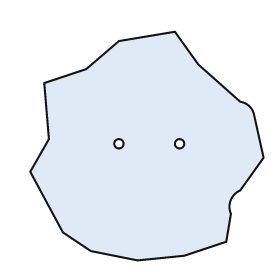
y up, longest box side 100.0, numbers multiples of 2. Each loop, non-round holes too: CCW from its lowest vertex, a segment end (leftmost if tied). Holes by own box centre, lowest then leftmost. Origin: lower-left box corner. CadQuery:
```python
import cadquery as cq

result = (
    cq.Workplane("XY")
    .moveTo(46.0, 0.0)
    .lineTo(66.0, 2.0)
    .lineTo(84.0, 8.0)
    .lineTo(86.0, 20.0)
    .threePointArc((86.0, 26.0), (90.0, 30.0))
    .lineTo(100.0, 44.0)
    .lineTo(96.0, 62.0)
    .threePointArc((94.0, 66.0), (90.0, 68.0))
    .lineTo(72.0, 84.0)
    .lineTo(62.0, 98.0)
    .lineTo(38.0, 94.0)
    .lineTo(24.0, 82.0)
    .lineTo(6.0, 76.0)
    .lineTo(8.0, 52.0)
    .lineTo(0.0, 38.0)
    .lineTo(14.0, 12.0)
    .lineTo(26.0, 4.0)
    .close()
    .moveTo(38.0, 50.0)
    .circle(2.0)
    .moveTo(64.0, 50.0)
    .circle(2.0)
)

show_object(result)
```